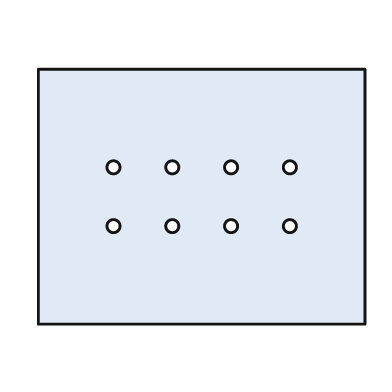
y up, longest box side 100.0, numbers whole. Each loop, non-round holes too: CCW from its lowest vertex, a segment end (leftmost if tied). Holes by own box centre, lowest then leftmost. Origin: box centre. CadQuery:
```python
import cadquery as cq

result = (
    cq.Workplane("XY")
    .moveTo(-50.0, -39.0)
    .lineTo(50.0, -39.0)
    .lineTo(50.0, 39.0)
    .lineTo(-50.0, 39.0)
    .close()
    .moveTo(-27.0, -9.0)
    .circle(2.0)
    .moveTo(-9.0, -9.0)
    .circle(2.0)
    .moveTo(9.0, -9.0)
    .circle(2.0)
    .moveTo(27.0, -9.0)
    .circle(2.0)
    .moveTo(-27.0, 9.0)
    .circle(2.0)
    .moveTo(-9.0, 9.0)
    .circle(2.0)
    .moveTo(9.0, 9.0)
    .circle(2.0)
    .moveTo(27.0, 9.0)
    .circle(2.0)
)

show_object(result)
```